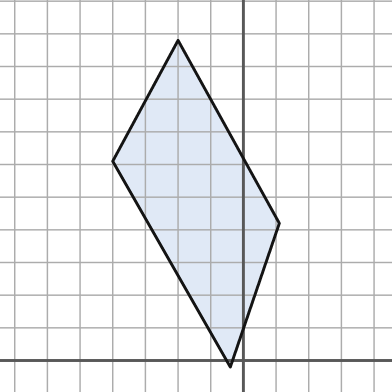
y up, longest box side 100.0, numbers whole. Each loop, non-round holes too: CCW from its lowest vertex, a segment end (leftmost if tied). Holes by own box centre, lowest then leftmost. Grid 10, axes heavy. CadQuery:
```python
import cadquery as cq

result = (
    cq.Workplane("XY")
    .moveTo(-4.0, -2.0)
    .lineTo(11.0, 42.0)
    .lineTo(-20.0, 98.0)
    .lineTo(-40.0, 61.0)
    .close()
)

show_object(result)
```